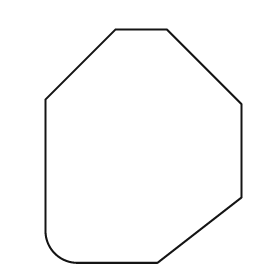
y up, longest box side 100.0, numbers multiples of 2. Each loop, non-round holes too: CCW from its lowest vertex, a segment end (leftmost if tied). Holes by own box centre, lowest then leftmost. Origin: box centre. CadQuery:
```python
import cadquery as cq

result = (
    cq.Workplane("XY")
    .moveTo(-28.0, -50.0)
    .lineTo(6.0, -50.0)
    .lineTo(42.0, -22.0)
    .lineTo(42.0, 18.0)
    .lineTo(10.0, 50.0)
    .lineTo(-12.0, 50.0)
    .lineTo(-42.0, 20.0)
    .lineTo(-42.0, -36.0)
    .threePointArc((-38.0, -46.0), (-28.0, -50.0))
    .close()
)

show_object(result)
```